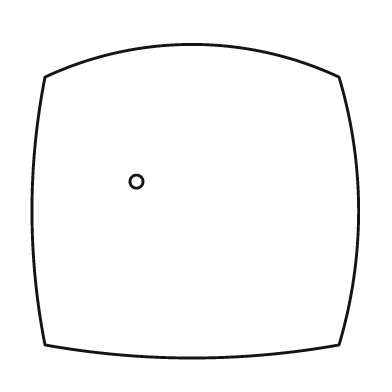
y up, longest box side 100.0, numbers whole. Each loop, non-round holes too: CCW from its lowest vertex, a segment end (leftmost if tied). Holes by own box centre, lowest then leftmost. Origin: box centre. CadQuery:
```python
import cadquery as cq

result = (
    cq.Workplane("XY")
    .moveTo(-46.0, -44.0)
    .threePointArc((-1.0, -48.0), (44.0, -44.0))
    .threePointArc((50.0, -3.0), (44.0, 38.0))
    .threePointArc((-1.0, 48.0), (-46.0, 38.0))
    .threePointArc((-50.0, -3.0), (-46.0, -44.0))
    .close()
    .moveTo(-18.0, 6.0)
    .circle(2.0)
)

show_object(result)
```